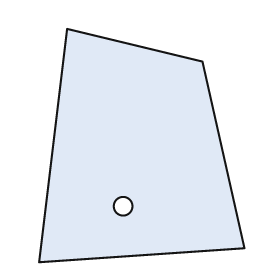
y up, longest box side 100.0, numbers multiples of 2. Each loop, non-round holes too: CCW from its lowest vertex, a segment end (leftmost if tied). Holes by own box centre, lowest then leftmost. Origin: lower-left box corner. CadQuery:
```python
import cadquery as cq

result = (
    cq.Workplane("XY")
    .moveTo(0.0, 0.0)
    .lineTo(88.0, 6.0)
    .lineTo(70.0, 86.0)
    .lineTo(12.0, 100.0)
    .close()
    .moveTo(36.0, 24.0)
    .circle(4.0)
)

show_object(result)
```